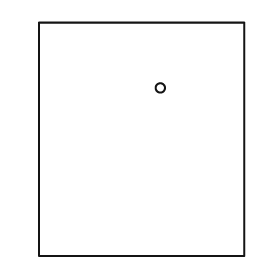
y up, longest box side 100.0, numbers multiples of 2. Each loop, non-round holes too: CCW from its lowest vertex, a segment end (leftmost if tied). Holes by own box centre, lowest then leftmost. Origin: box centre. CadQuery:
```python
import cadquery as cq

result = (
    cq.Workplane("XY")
    .moveTo(-44.0, -50.0)
    .lineTo(44.0, -50.0)
    .lineTo(44.0, 50.0)
    .lineTo(-44.0, 50.0)
    .close()
    .moveTo(8.0, 22.0)
    .circle(2.0)
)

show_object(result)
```